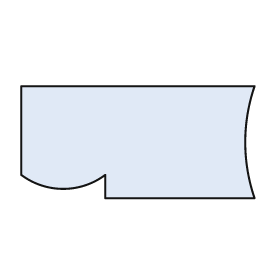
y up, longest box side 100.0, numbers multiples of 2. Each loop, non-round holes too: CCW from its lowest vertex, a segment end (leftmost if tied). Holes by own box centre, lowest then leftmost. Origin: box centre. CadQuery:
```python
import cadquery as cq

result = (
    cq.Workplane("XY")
    .moveTo(-14.0, -24.0)
    .lineTo(50.0, -24.0)
    .threePointArc((46.0, 0.0), (50.0, 24.0))
    .lineTo(-50.0, 24.0)
    .lineTo(-50.0, -14.0)
    .threePointArc((-32.0, -20.0), (-14.0, -14.0))
    .close()
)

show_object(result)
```